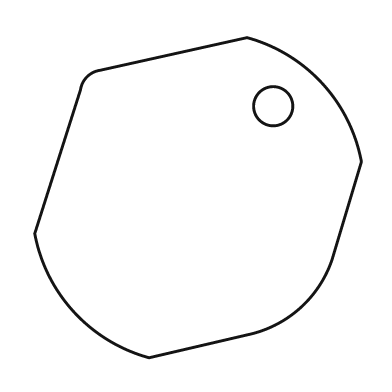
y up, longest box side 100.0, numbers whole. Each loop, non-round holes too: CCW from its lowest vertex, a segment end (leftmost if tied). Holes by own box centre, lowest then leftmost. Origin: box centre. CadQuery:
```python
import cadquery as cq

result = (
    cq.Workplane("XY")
    .moveTo(-15.0, -49.0)
    .lineTo(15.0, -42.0)
    .threePointArc((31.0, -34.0), (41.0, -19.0))
    .lineTo(50.0, 11.0)
    .threePointArc((38.0, 35.0), (15.0, 49.0))
    .lineTo(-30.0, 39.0)
    .threePointArc((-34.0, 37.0), (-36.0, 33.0))
    .lineTo(-50.0, -11.0)
    .threePointArc((-38.0, -35.0), (-15.0, -49.0))
    .close()
    .moveTo(23.0, 28.0)
    .circle(6.0)
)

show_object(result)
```